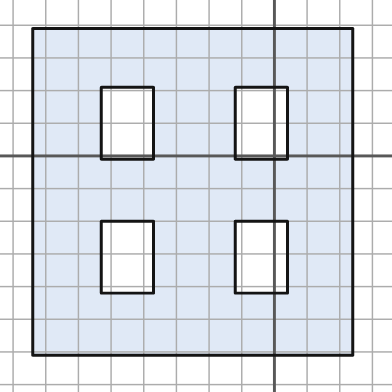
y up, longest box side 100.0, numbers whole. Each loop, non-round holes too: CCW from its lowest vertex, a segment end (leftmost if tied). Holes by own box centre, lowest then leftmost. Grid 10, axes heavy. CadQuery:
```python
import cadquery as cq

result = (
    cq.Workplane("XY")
    .moveTo(-74.0, -61.0)
    .lineTo(24.0, -61.0)
    .lineTo(24.0, 39.0)
    .lineTo(-74.0, 39.0)
    .close()
    .moveTo(-53.0, -42.0)
    .lineTo(-37.0, -42.0)
    .lineTo(-37.0, -20.0)
    .lineTo(-53.0, -20.0)
    .close()
    .moveTo(-12.0, -42.0)
    .lineTo(4.0, -42.0)
    .lineTo(4.0, -20.0)
    .lineTo(-12.0, -20.0)
    .close()
    .moveTo(-53.0, -1.0)
    .lineTo(-37.0, -1.0)
    .lineTo(-37.0, 21.0)
    .lineTo(-53.0, 21.0)
    .close()
    .moveTo(-12.0, -1.0)
    .lineTo(4.0, -1.0)
    .lineTo(4.0, 21.0)
    .lineTo(-12.0, 21.0)
    .close()
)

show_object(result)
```